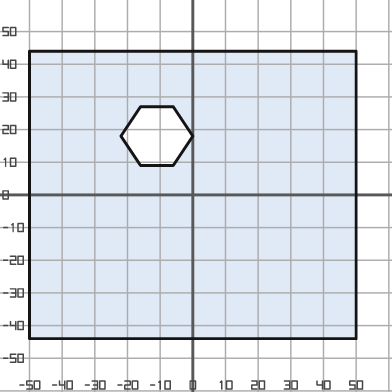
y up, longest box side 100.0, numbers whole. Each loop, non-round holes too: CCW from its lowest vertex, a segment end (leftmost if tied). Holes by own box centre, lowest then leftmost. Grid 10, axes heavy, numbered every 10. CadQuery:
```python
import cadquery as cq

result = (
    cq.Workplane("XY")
    .moveTo(-50.0, -44.0)
    .lineTo(50.0, -44.0)
    .lineTo(50.0, 44.0)
    .lineTo(-50.0, 44.0)
    .close()
    .moveTo(-16.0, 9.0)
    .lineTo(-6.0, 9.0)
    .lineTo(0.0, 18.0)
    .lineTo(-6.0, 27.0)
    .lineTo(-16.0, 27.0)
    .lineTo(-22.0, 18.0)
    .close()
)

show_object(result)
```